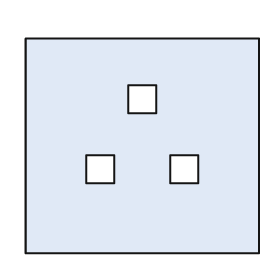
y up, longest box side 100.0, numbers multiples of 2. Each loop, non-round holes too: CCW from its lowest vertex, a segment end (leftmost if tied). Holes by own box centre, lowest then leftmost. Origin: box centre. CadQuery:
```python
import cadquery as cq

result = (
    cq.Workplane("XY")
    .moveTo(-50.0, -46.0)
    .lineTo(50.0, -46.0)
    .lineTo(50.0, 46.0)
    .lineTo(-50.0, 46.0)
    .close()
    .moveTo(-24.0, -16.0)
    .lineTo(-12.0, -16.0)
    .lineTo(-12.0, -4.0)
    .lineTo(-24.0, -4.0)
    .close()
    .moveTo(12.0, -16.0)
    .lineTo(24.0, -16.0)
    .lineTo(24.0, -4.0)
    .lineTo(12.0, -4.0)
    .close()
    .moveTo(-6.0, 14.0)
    .lineTo(6.0, 14.0)
    .lineTo(6.0, 26.0)
    .lineTo(-6.0, 26.0)
    .close()
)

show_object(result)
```